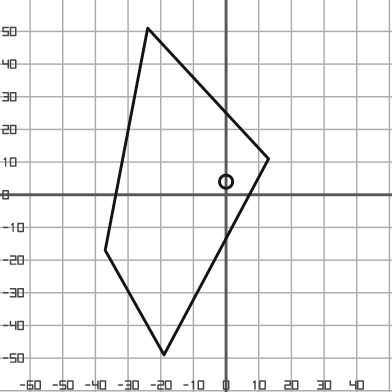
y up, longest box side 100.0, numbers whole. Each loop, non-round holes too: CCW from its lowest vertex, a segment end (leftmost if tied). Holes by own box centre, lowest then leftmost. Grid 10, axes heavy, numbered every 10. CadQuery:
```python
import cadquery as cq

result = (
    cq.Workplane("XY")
    .moveTo(-19.0, -49.0)
    .lineTo(13.0, 11.0)
    .lineTo(-24.0, 51.0)
    .lineTo(-37.0, -17.0)
    .close()
    .moveTo(0.0, 4.0)
    .circle(2.0)
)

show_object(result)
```